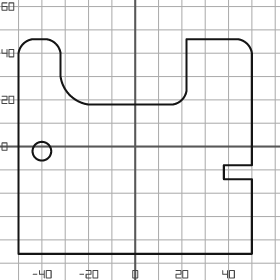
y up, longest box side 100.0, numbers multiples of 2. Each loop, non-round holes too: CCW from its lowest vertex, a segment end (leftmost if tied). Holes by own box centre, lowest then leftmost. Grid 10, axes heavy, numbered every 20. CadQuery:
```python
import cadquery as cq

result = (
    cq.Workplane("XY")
    .moveTo(-50.0, -46.0)
    .lineTo(50.0, -46.0)
    .lineTo(50.0, -14.0)
    .lineTo(38.0, -14.0)
    .lineTo(38.0, -8.0)
    .lineTo(50.0, -8.0)
    .lineTo(50.0, 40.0)
    .threePointArc((48.0, 44.0), (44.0, 46.0))
    .lineTo(22.0, 46.0)
    .lineTo(22.0, 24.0)
    .threePointArc((20.0, 20.0), (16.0, 18.0))
    .lineTo(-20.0, 18.0)
    .threePointArc((-28.0, 22.0), (-32.0, 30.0))
    .lineTo(-32.0, 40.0)
    .threePointArc((-34.0, 44.0), (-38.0, 46.0))
    .lineTo(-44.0, 46.0)
    .threePointArc((-48.0, 44.0), (-50.0, 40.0))
    .close()
    .moveTo(-40.0, -2.0)
    .circle(4.0)
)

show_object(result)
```